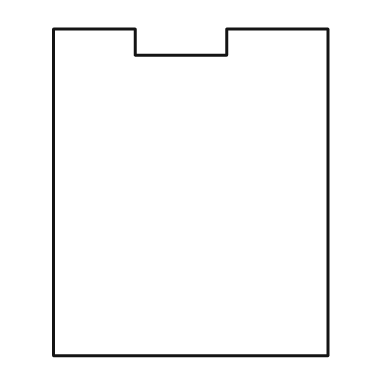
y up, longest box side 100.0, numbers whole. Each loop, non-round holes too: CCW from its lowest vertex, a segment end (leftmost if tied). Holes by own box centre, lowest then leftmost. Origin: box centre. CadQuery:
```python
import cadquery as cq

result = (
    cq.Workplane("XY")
    .moveTo(-42.0, -50.0)
    .lineTo(42.0, -50.0)
    .lineTo(42.0, 50.0)
    .lineTo(11.0, 50.0)
    .lineTo(11.0, 42.0)
    .lineTo(-17.0, 42.0)
    .lineTo(-17.0, 50.0)
    .lineTo(-42.0, 50.0)
    .close()
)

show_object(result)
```